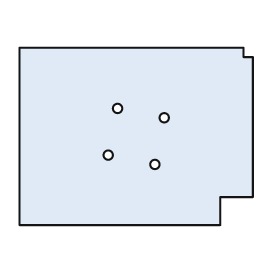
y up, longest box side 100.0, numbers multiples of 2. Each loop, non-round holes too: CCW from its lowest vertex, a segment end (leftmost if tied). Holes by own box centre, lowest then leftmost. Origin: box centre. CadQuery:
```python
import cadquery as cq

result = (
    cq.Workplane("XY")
    .moveTo(-50.0, -38.0)
    .lineTo(36.0, -38.0)
    .lineTo(36.0, -26.0)
    .lineTo(50.0, -26.0)
    .lineTo(50.0, 34.0)
    .lineTo(46.0, 34.0)
    .lineTo(46.0, 38.0)
    .lineTo(-50.0, 38.0)
    .close()
    .moveTo(8.0, -12.0)
    .circle(2.0)
    .moveTo(-12.0, -8.0)
    .circle(2.0)
    .moveTo(12.0, 8.0)
    .circle(2.0)
    .moveTo(-8.0, 12.0)
    .circle(2.0)
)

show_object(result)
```